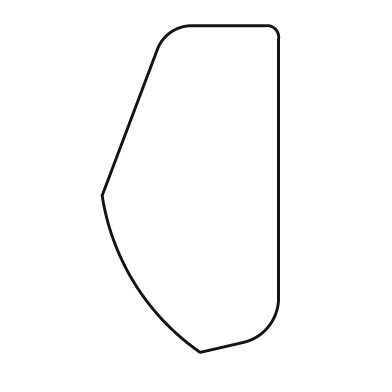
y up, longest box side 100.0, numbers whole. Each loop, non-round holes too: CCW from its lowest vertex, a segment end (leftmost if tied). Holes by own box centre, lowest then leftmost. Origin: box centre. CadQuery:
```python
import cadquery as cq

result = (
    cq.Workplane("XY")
    .moveTo(3.0, -50.0)
    .lineTo(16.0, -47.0)
    .threePointArc((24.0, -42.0), (27.0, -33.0))
    .lineTo(27.0, 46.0)
    .threePointArc((26.0, 49.0), (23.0, 50.0))
    .lineTo(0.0, 50.0)
    .threePointArc((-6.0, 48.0), (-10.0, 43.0))
    .lineTo(-27.0, -2.0)
    .threePointArc((-17.0, -29.0), (3.0, -50.0))
    .close()
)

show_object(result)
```